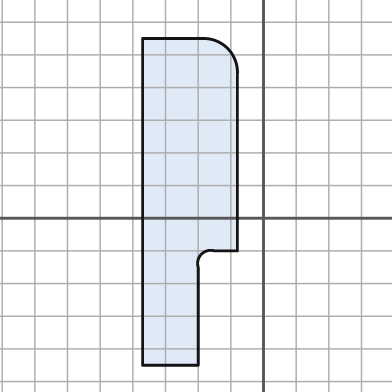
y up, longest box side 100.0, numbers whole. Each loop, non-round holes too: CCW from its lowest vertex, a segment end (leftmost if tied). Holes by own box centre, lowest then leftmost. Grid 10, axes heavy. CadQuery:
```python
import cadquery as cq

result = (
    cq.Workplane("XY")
    .moveTo(-37.0, -45.0)
    .lineTo(-20.0, -45.0)
    .lineTo(-20.0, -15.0)
    .threePointArc((-19.0, -11.0), (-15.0, -10.0))
    .lineTo(-8.0, -10.0)
    .lineTo(-8.0, 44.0)
    .threePointArc((-11.0, 52.0), (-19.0, 55.0))
    .lineTo(-37.0, 55.0)
    .close()
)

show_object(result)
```